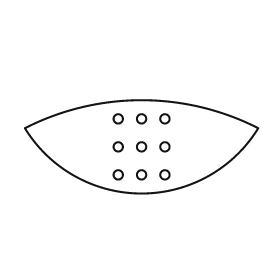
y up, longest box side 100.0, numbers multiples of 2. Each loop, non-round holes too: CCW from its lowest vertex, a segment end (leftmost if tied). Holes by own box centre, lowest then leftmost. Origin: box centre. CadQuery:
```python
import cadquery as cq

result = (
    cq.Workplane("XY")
    .moveTo(-50.0, 8.0)
    .threePointArc((0.0, -20.0), (50.0, 8.0))
    .threePointArc((0.0, 20.0), (-50.0, 8.0))
    .close()
    .moveTo(-10.0, -12.0)
    .circle(2.0)
    .moveTo(0.0, -12.0)
    .circle(2.0)
    .moveTo(10.0, -12.0)
    .circle(2.0)
    .moveTo(-10.0, 0.0)
    .circle(2.0)
    .moveTo(0.0, 0.0)
    .circle(2.0)
    .moveTo(10.0, 0.0)
    .circle(2.0)
    .moveTo(-10.0, 12.0)
    .circle(2.0)
    .moveTo(0.0, 12.0)
    .circle(2.0)
    .moveTo(10.0, 12.0)
    .circle(2.0)
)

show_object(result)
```